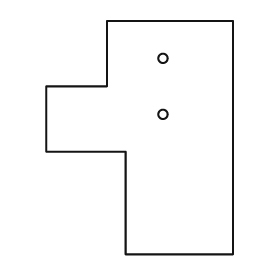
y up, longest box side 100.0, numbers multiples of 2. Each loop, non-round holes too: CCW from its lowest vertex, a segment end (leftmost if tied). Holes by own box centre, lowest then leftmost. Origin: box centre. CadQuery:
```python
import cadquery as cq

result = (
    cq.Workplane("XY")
    .moveTo(-6.0, -50.0)
    .lineTo(40.0, -50.0)
    .lineTo(40.0, 50.0)
    .lineTo(-14.0, 50.0)
    .lineTo(-14.0, 22.0)
    .lineTo(-40.0, 22.0)
    .lineTo(-40.0, -6.0)
    .lineTo(-6.0, -6.0)
    .close()
    .moveTo(10.0, 10.0)
    .circle(2.0)
    .moveTo(10.0, 34.0)
    .circle(2.0)
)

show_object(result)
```